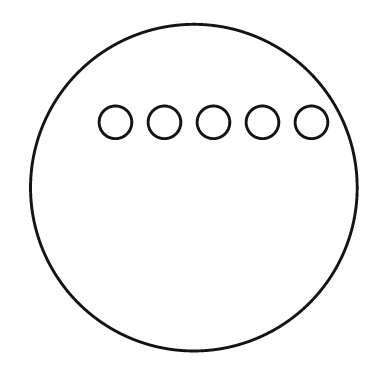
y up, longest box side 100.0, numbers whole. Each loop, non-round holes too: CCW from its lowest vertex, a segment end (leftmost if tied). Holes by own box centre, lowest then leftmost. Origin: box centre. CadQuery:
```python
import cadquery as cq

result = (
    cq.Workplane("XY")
    .moveTo(0.0, 0.0)
    .circle(50.0)
    .moveTo(-24.0, 20.0)
    .circle(5.0)
    .moveTo(-9.0, 20.0)
    .circle(5.0)
    .moveTo(6.0, 20.0)
    .circle(5.0)
    .moveTo(21.0, 20.0)
    .circle(5.0)
    .moveTo(36.0, 20.0)
    .circle(5.0)
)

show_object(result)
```